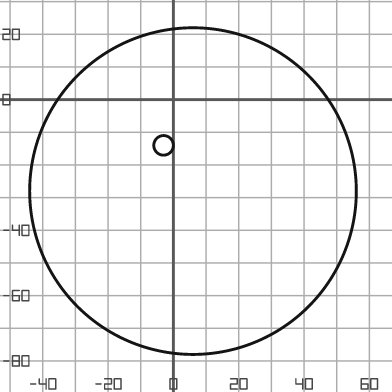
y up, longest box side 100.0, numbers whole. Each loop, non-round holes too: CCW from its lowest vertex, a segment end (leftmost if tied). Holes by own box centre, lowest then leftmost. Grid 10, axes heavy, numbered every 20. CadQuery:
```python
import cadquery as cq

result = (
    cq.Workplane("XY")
    .moveTo(6.0, -28.0)
    .circle(50.0)
    .moveTo(-3.0, -14.0)
    .circle(3.0)
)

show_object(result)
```